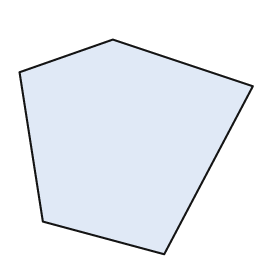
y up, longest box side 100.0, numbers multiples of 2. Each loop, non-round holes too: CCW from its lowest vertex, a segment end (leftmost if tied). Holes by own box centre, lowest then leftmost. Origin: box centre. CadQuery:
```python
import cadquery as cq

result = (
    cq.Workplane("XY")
    .moveTo(12.0, -46.0)
    .lineTo(50.0, 26.0)
    .lineTo(-10.0, 46.0)
    .lineTo(-50.0, 32.0)
    .lineTo(-40.0, -32.0)
    .close()
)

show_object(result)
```